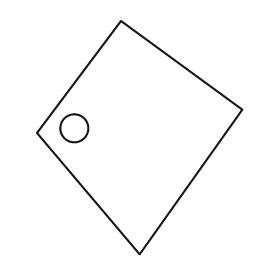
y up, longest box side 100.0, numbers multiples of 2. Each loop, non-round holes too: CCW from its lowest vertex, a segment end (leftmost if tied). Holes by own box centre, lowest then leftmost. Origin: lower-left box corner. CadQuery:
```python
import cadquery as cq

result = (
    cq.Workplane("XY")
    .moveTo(44.0, 0.0)
    .lineTo(88.0, 62.0)
    .lineTo(36.0, 100.0)
    .lineTo(0.0, 52.0)
    .close()
    .moveTo(16.0, 54.0)
    .circle(6.0)
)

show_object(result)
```